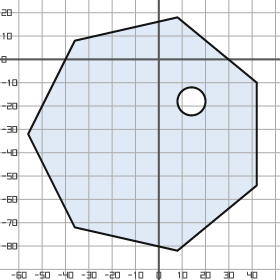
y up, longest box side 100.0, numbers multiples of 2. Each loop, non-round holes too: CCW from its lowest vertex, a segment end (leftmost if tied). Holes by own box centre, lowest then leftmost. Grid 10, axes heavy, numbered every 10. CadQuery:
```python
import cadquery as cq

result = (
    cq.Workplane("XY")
    .moveTo(8.0, -82.0)
    .lineTo(42.0, -54.0)
    .lineTo(42.0, -10.0)
    .lineTo(8.0, 18.0)
    .lineTo(-36.0, 8.0)
    .lineTo(-56.0, -32.0)
    .lineTo(-36.0, -72.0)
    .close()
    .moveTo(14.0, -18.0)
    .circle(6.0)
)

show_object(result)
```